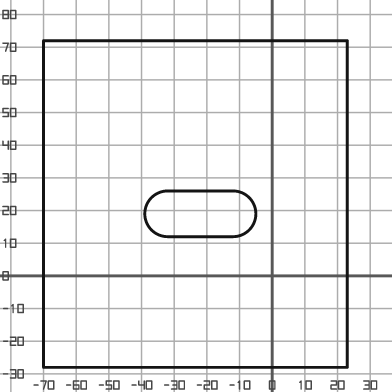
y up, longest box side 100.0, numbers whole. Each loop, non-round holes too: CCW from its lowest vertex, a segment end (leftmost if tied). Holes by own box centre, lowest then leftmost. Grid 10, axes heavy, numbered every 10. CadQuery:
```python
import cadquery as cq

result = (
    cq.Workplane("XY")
    .moveTo(-70.0, -28.0)
    .lineTo(23.0, -28.0)
    .lineTo(23.0, 72.0)
    .lineTo(-70.0, 72.0)
    .close()
    .moveTo(-32.0, 12.0)
    .lineTo(-12.0, 12.0)
    .threePointArc((-5.0, 19.0), (-12.0, 26.0))
    .lineTo(-32.0, 26.0)
    .threePointArc((-39.0, 19.0), (-32.0, 12.0))
    .close()
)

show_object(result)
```